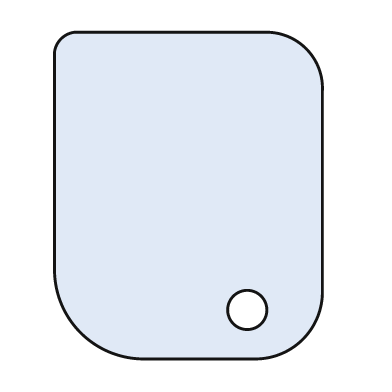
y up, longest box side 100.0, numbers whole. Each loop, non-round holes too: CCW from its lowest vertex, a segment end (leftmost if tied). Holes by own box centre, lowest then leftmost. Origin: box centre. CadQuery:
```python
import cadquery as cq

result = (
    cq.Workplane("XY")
    .moveTo(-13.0, -50.0)
    .lineTo(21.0, -50.0)
    .threePointArc((35.0, -44.0), (41.0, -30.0))
    .lineTo(41.0, 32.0)
    .threePointArc((36.0, 45.0), (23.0, 50.0))
    .lineTo(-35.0, 50.0)
    .threePointArc((-39.0, 48.0), (-41.0, 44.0))
    .lineTo(-41.0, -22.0)
    .threePointArc((-33.0, -42.0), (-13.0, -50.0))
    .close()
    .moveTo(18.0, -35.0)
    .circle(6.0)
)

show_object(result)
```